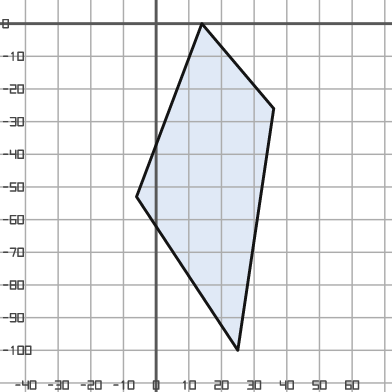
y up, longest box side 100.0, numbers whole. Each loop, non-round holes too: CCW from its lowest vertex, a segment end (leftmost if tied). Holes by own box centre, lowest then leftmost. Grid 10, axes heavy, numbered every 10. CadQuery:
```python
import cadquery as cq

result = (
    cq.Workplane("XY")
    .moveTo(25.0, -100.0)
    .lineTo(36.0, -26.0)
    .lineTo(14.0, 0.0)
    .lineTo(-6.0, -53.0)
    .close()
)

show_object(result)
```